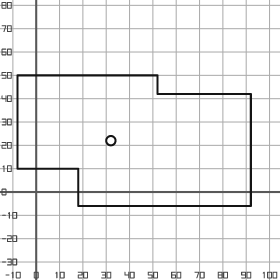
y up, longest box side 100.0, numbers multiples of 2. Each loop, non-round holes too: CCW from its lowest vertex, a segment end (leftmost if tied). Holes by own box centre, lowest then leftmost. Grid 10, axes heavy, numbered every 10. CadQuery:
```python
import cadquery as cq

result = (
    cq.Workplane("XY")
    .moveTo(18.0, -6.0)
    .lineTo(92.0, -6.0)
    .lineTo(92.0, 42.0)
    .lineTo(52.0, 42.0)
    .lineTo(52.0, 50.0)
    .lineTo(-8.0, 50.0)
    .lineTo(-8.0, 10.0)
    .lineTo(18.0, 10.0)
    .close()
    .moveTo(32.0, 22.0)
    .circle(2.0)
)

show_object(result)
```